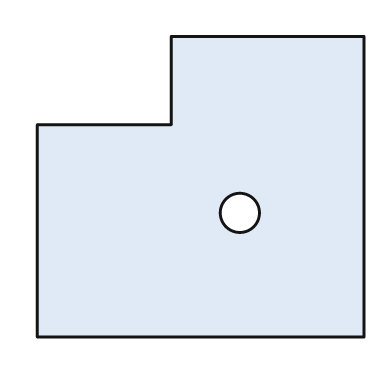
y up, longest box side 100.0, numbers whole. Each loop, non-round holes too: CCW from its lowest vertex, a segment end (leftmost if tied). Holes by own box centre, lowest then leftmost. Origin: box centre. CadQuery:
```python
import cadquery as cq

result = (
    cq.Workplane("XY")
    .moveTo(-50.0, -46.0)
    .lineTo(50.0, -46.0)
    .lineTo(50.0, 46.0)
    .lineTo(-9.0, 46.0)
    .lineTo(-9.0, 19.0)
    .lineTo(-50.0, 19.0)
    .close()
    .moveTo(12.0, -8.0)
    .circle(6.0)
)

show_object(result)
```